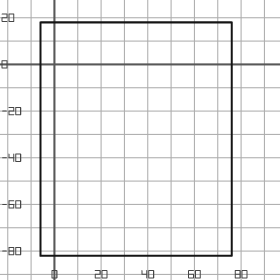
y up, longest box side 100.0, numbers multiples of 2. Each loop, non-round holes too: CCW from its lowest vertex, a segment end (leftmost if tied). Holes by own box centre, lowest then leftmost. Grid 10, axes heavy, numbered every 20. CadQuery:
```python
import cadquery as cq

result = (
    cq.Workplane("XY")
    .moveTo(-6.0, -82.0)
    .lineTo(76.0, -82.0)
    .lineTo(76.0, 18.0)
    .lineTo(-6.0, 18.0)
    .close()
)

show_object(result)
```